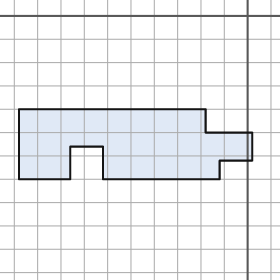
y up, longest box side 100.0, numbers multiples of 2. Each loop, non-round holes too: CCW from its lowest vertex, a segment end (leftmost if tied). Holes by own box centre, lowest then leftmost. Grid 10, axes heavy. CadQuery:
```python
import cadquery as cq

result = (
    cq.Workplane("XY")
    .moveTo(-98.0, -70.0)
    .lineTo(-76.0, -70.0)
    .lineTo(-76.0, -56.0)
    .lineTo(-62.0, -56.0)
    .lineTo(-62.0, -70.0)
    .lineTo(-12.0, -70.0)
    .lineTo(-12.0, -62.0)
    .lineTo(2.0, -62.0)
    .lineTo(2.0, -50.0)
    .lineTo(-18.0, -50.0)
    .lineTo(-18.0, -40.0)
    .lineTo(-98.0, -40.0)
    .close()
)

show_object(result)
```